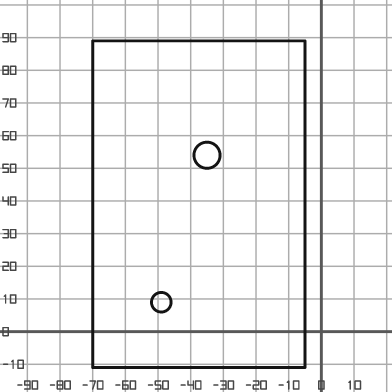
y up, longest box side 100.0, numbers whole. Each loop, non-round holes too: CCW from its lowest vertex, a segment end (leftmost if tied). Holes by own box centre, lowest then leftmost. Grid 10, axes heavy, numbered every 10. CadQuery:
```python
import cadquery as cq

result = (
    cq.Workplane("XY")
    .moveTo(-70.0, -11.0)
    .lineTo(-5.0, -11.0)
    .lineTo(-5.0, 89.0)
    .lineTo(-70.0, 89.0)
    .close()
    .moveTo(-49.0, 9.0)
    .circle(3.0)
    .moveTo(-35.0, 54.0)
    .circle(4.0)
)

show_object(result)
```